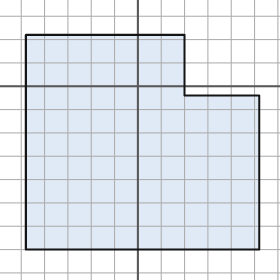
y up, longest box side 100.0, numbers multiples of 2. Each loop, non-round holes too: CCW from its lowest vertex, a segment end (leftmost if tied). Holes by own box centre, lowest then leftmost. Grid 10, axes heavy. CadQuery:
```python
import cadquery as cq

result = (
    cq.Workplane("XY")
    .moveTo(-48.0, -70.0)
    .lineTo(52.0, -70.0)
    .lineTo(52.0, -4.0)
    .lineTo(20.0, -4.0)
    .lineTo(20.0, 22.0)
    .lineTo(-48.0, 22.0)
    .close()
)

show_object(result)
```